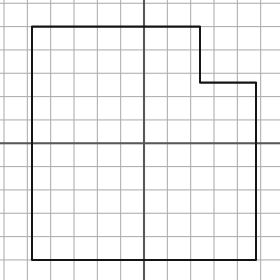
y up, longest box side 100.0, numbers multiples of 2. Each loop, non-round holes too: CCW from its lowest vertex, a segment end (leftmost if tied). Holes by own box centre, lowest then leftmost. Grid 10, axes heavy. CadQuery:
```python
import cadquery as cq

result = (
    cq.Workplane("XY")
    .moveTo(-48.0, -50.0)
    .lineTo(48.0, -50.0)
    .lineTo(48.0, 26.0)
    .lineTo(24.0, 26.0)
    .lineTo(24.0, 50.0)
    .lineTo(-48.0, 50.0)
    .close()
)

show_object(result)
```